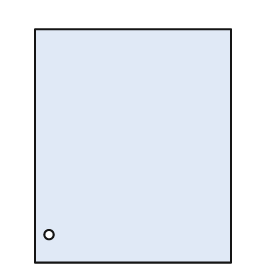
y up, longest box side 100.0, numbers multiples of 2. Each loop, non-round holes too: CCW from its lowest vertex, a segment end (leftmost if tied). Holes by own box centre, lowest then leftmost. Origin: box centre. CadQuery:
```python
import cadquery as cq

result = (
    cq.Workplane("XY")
    .moveTo(-42.0, -50.0)
    .lineTo(42.0, -50.0)
    .lineTo(42.0, 50.0)
    .lineTo(-42.0, 50.0)
    .close()
    .moveTo(-36.0, -38.0)
    .circle(2.0)
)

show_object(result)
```